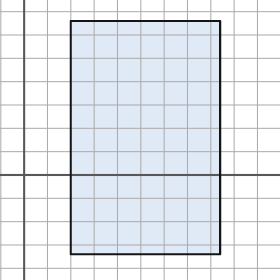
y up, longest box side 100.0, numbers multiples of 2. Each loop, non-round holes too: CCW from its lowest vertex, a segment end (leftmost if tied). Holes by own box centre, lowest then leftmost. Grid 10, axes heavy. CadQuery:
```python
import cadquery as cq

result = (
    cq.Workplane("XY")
    .moveTo(20.0, -34.0)
    .lineTo(84.0, -34.0)
    .lineTo(84.0, 66.0)
    .lineTo(20.0, 66.0)
    .close()
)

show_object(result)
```